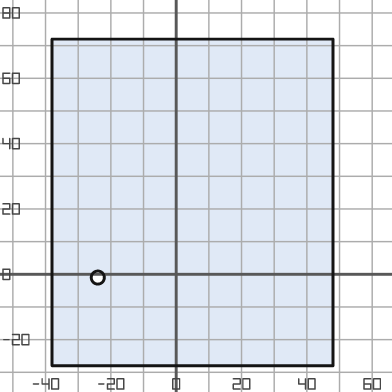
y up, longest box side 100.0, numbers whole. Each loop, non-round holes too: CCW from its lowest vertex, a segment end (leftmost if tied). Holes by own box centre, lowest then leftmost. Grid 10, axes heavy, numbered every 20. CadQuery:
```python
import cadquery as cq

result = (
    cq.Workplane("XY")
    .moveTo(-38.0, -28.0)
    .lineTo(48.0, -28.0)
    .lineTo(48.0, 72.0)
    .lineTo(-38.0, 72.0)
    .close()
    .moveTo(-24.0, -1.0)
    .circle(2.0)
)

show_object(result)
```